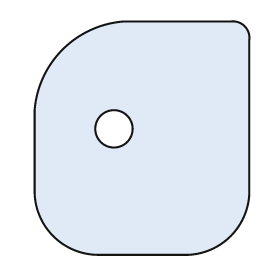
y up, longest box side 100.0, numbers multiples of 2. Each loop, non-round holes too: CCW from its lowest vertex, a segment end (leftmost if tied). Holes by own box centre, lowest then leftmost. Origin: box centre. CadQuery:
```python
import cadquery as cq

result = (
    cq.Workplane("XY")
    .moveTo(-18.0, -50.0)
    .lineTo(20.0, -50.0)
    .threePointArc((38.0, -42.0), (46.0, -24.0))
    .lineTo(46.0, 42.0)
    .threePointArc((44.0, 48.0), (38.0, 50.0))
    .lineTo(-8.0, 50.0)
    .threePointArc((-34.0, 38.0), (-46.0, 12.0))
    .lineTo(-46.0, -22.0)
    .threePointArc((-38.0, -42.0), (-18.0, -50.0))
    .close()
    .moveTo(-12.0, 4.0)
    .circle(8.0)
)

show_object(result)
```